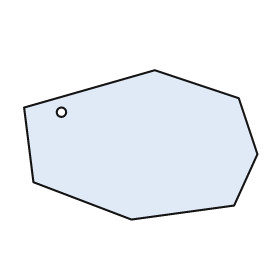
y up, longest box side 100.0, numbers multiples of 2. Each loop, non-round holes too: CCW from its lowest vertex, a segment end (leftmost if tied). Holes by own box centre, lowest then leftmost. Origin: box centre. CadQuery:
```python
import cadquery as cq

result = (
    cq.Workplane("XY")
    .moveTo(-4.0, -32.0)
    .lineTo(40.0, -26.0)
    .lineTo(50.0, -4.0)
    .lineTo(42.0, 20.0)
    .lineTo(6.0, 32.0)
    .lineTo(-50.0, 16.0)
    .lineTo(-46.0, -16.0)
    .close()
    .moveTo(-34.0, 14.0)
    .circle(2.0)
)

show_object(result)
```